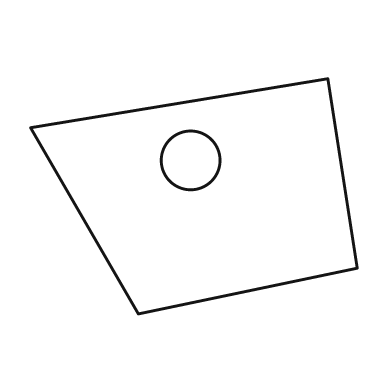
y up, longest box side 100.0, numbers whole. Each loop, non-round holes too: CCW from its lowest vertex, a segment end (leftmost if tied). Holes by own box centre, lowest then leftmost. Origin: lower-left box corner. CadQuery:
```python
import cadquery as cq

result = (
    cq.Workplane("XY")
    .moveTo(33.0, 0.0)
    .lineTo(100.0, 14.0)
    .lineTo(91.0, 72.0)
    .lineTo(0.0, 57.0)
    .close()
    .moveTo(49.0, 47.0)
    .circle(9.0)
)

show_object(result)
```